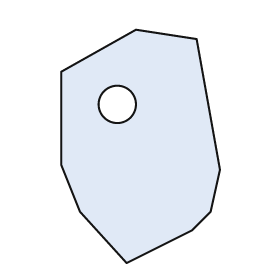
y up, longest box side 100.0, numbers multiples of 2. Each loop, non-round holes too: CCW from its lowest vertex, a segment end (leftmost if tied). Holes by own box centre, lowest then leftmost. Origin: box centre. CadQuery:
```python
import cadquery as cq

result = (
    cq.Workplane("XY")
    .moveTo(-6.0, -50.0)
    .lineTo(22.0, -36.0)
    .lineTo(30.0, -28.0)
    .lineTo(34.0, -10.0)
    .lineTo(24.0, 46.0)
    .lineTo(-2.0, 50.0)
    .lineTo(-34.0, 32.0)
    .lineTo(-34.0, -8.0)
    .lineTo(-26.0, -28.0)
    .close()
    .moveTo(-10.0, 18.0)
    .circle(8.0)
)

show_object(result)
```